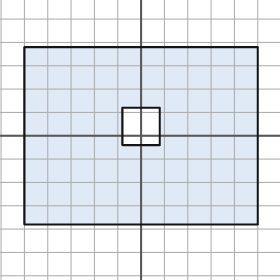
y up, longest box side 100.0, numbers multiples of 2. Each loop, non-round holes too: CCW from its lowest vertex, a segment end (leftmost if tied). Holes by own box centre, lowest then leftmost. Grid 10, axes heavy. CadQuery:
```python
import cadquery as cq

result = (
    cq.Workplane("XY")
    .moveTo(-50.0, -38.0)
    .lineTo(50.0, -38.0)
    .lineTo(50.0, 38.0)
    .lineTo(-50.0, 38.0)
    .close()
    .moveTo(-8.0, -4.0)
    .lineTo(8.0, -4.0)
    .lineTo(8.0, 12.0)
    .lineTo(-8.0, 12.0)
    .close()
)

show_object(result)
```